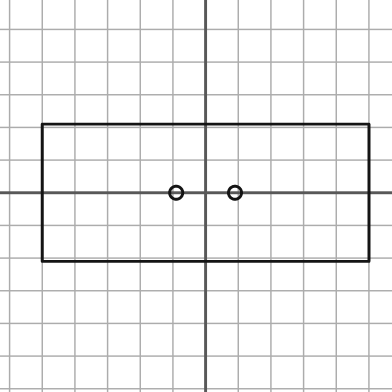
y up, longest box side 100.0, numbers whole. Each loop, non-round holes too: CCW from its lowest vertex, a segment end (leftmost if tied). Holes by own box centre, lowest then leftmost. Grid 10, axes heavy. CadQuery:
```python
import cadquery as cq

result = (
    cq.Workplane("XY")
    .moveTo(-50.0, -21.0)
    .lineTo(50.0, -21.0)
    .lineTo(50.0, 21.0)
    .lineTo(-50.0, 21.0)
    .close()
    .moveTo(-9.0, 0.0)
    .circle(2.0)
    .moveTo(9.0, 0.0)
    .circle(2.0)
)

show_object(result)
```